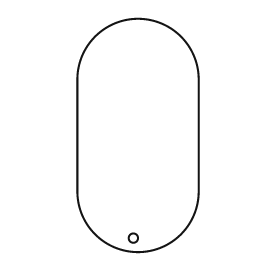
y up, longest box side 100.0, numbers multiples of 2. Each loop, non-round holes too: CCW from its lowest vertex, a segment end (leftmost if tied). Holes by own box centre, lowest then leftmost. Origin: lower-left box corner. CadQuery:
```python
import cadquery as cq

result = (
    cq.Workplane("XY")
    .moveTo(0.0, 26.0)
    .threePointArc((26.0, 0.0), (52.0, 26.0))
    .lineTo(52.0, 74.0)
    .threePointArc((26.0, 100.0), (0.0, 74.0))
    .close()
    .moveTo(24.0, 6.0)
    .circle(2.0)
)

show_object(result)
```